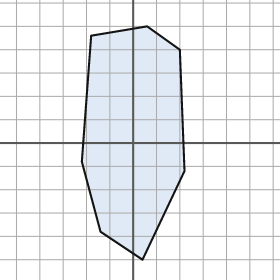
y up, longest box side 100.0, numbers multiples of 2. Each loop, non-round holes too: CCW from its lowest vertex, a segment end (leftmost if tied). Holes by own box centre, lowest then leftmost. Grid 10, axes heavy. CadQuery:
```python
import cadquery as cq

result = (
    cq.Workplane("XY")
    .moveTo(4.0, -50.0)
    .lineTo(22.0, -12.0)
    .lineTo(20.0, 40.0)
    .lineTo(6.0, 50.0)
    .lineTo(-18.0, 46.0)
    .lineTo(-22.0, -8.0)
    .lineTo(-14.0, -38.0)
    .close()
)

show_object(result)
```